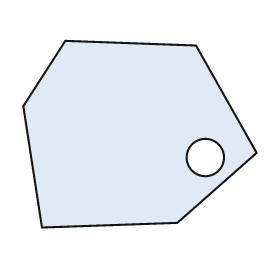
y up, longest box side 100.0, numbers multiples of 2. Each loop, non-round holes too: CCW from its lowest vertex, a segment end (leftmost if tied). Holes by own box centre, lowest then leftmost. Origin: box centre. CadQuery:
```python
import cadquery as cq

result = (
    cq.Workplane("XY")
    .moveTo(-42.0, -40.0)
    .lineTo(16.0, -38.0)
    .lineTo(50.0, -8.0)
    .lineTo(24.0, 38.0)
    .lineTo(-32.0, 40.0)
    .lineTo(-50.0, 12.0)
    .close()
    .moveTo(28.0, -10.0)
    .circle(8.0)
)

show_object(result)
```